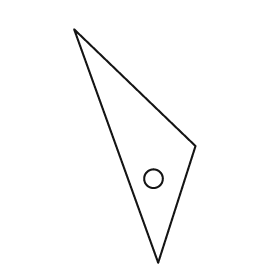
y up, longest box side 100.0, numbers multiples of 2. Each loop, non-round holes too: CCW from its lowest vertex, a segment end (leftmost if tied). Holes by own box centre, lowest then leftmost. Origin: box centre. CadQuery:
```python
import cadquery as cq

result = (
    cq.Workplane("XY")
    .moveTo(10.0, -50.0)
    .lineTo(26.0, 0.0)
    .lineTo(-26.0, 50.0)
    .close()
    .moveTo(8.0, -14.0)
    .circle(4.0)
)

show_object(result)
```